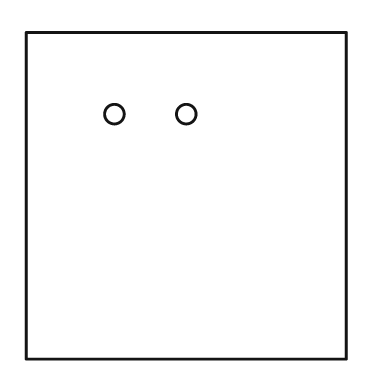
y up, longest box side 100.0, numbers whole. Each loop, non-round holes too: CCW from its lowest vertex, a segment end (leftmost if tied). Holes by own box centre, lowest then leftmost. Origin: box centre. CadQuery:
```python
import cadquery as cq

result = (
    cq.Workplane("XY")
    .moveTo(-49.0, -50.0)
    .lineTo(49.0, -50.0)
    .lineTo(49.0, 50.0)
    .lineTo(-49.0, 50.0)
    .close()
    .moveTo(-22.0, 25.0)
    .circle(3.0)
    .moveTo(0.0, 25.0)
    .circle(3.0)
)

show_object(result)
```